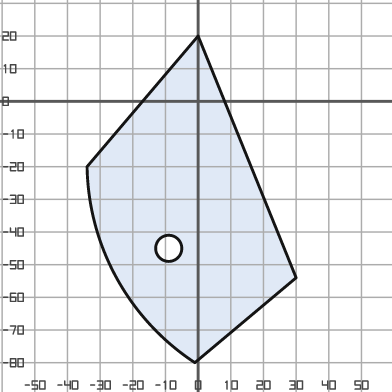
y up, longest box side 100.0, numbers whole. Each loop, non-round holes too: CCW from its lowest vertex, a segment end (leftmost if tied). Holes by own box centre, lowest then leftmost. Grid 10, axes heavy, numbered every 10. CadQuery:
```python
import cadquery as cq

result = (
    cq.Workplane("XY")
    .moveTo(-1.0, -80.0)
    .lineTo(30.0, -54.0)
    .lineTo(0.0, 20.0)
    .lineTo(-34.0, -20.0)
    .threePointArc((-25.0, -54.0), (-1.0, -80.0))
    .close()
    .moveTo(-9.0, -45.0)
    .circle(4.0)
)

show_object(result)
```